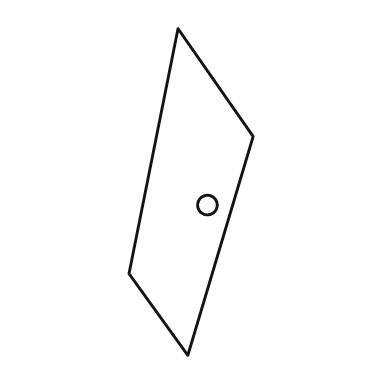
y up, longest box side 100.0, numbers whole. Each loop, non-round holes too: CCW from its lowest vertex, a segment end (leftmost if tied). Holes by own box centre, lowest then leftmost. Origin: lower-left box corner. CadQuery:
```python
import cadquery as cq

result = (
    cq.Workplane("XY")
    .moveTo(18.0, 0.0)
    .lineTo(38.0, 67.0)
    .lineTo(15.0, 100.0)
    .lineTo(0.0, 25.0)
    .close()
    .moveTo(24.0, 46.0)
    .circle(3.0)
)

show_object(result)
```